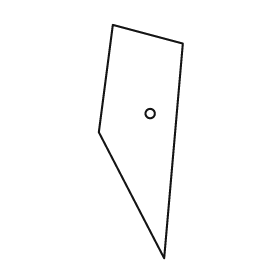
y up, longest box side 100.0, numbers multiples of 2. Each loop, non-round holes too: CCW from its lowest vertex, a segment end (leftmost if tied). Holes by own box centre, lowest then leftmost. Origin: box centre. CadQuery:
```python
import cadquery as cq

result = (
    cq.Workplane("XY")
    .moveTo(10.0, -50.0)
    .lineTo(18.0, 42.0)
    .lineTo(-12.0, 50.0)
    .lineTo(-18.0, 4.0)
    .close()
    .moveTo(4.0, 12.0)
    .circle(2.0)
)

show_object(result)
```